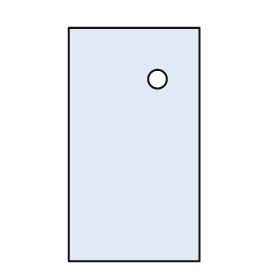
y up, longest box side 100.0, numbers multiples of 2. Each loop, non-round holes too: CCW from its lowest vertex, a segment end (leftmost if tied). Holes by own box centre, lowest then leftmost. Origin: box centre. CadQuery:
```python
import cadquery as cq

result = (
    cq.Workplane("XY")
    .moveTo(-28.0, -50.0)
    .lineTo(28.0, -50.0)
    .lineTo(28.0, 50.0)
    .lineTo(-28.0, 50.0)
    .close()
    .moveTo(10.0, 28.0)
    .circle(4.0)
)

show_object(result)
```